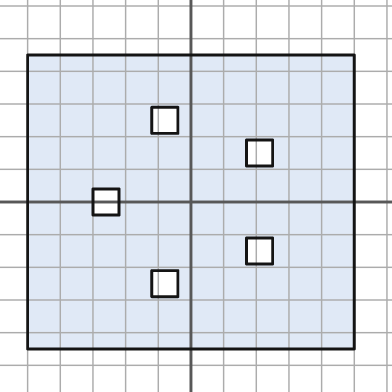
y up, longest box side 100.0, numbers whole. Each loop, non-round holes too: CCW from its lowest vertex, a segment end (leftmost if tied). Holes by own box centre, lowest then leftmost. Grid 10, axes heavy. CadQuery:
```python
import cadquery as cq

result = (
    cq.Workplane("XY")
    .moveTo(-50.0, -45.0)
    .lineTo(50.0, -45.0)
    .lineTo(50.0, 45.0)
    .lineTo(-50.0, 45.0)
    .close()
    .moveTo(-12.0, -29.0)
    .lineTo(-4.0, -29.0)
    .lineTo(-4.0, -21.0)
    .lineTo(-12.0, -21.0)
    .close()
    .moveTo(17.0, -19.0)
    .lineTo(25.0, -19.0)
    .lineTo(25.0, -11.0)
    .lineTo(17.0, -11.0)
    .close()
    .moveTo(-30.0, -4.0)
    .lineTo(-22.0, -4.0)
    .lineTo(-22.0, 4.0)
    .lineTo(-30.0, 4.0)
    .close()
    .moveTo(17.0, 11.0)
    .lineTo(25.0, 11.0)
    .lineTo(25.0, 19.0)
    .lineTo(17.0, 19.0)
    .close()
    .moveTo(-12.0, 21.0)
    .lineTo(-4.0, 21.0)
    .lineTo(-4.0, 29.0)
    .lineTo(-12.0, 29.0)
    .close()
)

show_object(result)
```